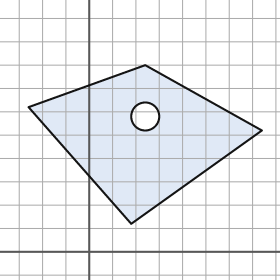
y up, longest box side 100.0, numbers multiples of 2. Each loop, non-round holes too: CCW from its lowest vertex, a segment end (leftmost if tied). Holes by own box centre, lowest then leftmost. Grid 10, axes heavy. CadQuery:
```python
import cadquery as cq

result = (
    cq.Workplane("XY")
    .moveTo(18.0, 12.0)
    .lineTo(74.0, 52.0)
    .lineTo(24.0, 80.0)
    .lineTo(-26.0, 62.0)
    .close()
    .moveTo(24.0, 58.0)
    .circle(6.0)
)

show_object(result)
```